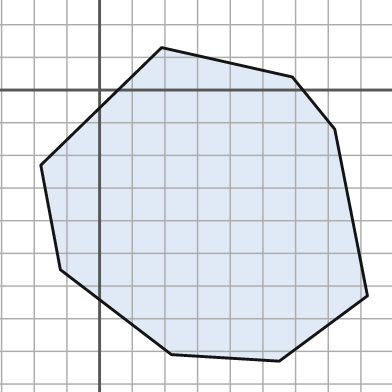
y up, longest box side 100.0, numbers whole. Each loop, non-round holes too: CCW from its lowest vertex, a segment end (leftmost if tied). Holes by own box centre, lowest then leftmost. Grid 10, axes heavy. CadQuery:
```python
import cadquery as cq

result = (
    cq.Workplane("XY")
    .moveTo(55.0, -83.0)
    .lineTo(82.0, -63.0)
    .lineTo(72.0, -12.0)
    .lineTo(59.0, 4.0)
    .lineTo(19.0, 13.0)
    .lineTo(-18.0, -23.0)
    .lineTo(-12.0, -55.0)
    .lineTo(22.0, -81.0)
    .close()
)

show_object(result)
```